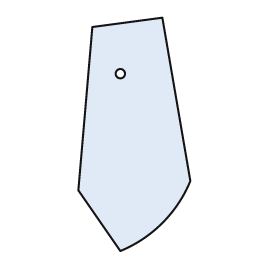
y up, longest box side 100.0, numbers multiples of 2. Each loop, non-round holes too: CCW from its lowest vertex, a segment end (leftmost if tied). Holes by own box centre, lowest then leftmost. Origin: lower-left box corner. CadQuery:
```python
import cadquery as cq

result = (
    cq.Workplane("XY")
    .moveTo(18.0, 0.0)
    .threePointArc((36.0, 12.0), (48.0, 30.0))
    .lineTo(36.0, 100.0)
    .lineTo(6.0, 96.0)
    .lineTo(0.0, 26.0)
    .close()
    .moveTo(18.0, 76.0)
    .circle(2.0)
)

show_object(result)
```